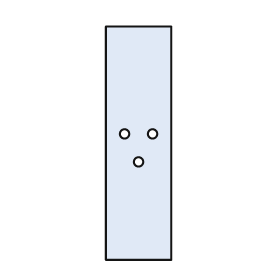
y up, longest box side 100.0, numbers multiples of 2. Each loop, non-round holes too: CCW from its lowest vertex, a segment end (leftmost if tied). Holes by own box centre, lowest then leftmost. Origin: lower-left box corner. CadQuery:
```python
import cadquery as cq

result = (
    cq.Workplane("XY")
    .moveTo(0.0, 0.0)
    .lineTo(28.0, 0.0)
    .lineTo(28.0, 100.0)
    .lineTo(0.0, 100.0)
    .close()
    .moveTo(14.0, 42.0)
    .circle(2.0)
    .moveTo(8.0, 54.0)
    .circle(2.0)
    .moveTo(20.0, 54.0)
    .circle(2.0)
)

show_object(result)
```